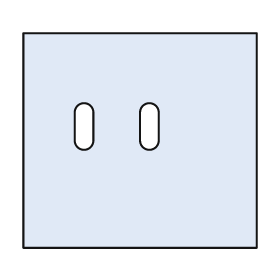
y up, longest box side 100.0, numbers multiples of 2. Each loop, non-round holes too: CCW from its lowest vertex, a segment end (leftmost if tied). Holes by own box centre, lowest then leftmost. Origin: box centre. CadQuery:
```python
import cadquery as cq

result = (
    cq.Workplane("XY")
    .moveTo(-50.0, -46.0)
    .lineTo(50.0, -46.0)
    .lineTo(50.0, 46.0)
    .lineTo(-50.0, 46.0)
    .close()
    .moveTo(-28.0, 0.0)
    .threePointArc((-24.0, -4.0), (-20.0, 0.0))
    .lineTo(-20.0, 12.0)
    .threePointArc((-24.0, 16.0), (-28.0, 12.0))
    .close()
    .moveTo(0.0, 0.0)
    .threePointArc((4.0, -4.0), (8.0, 0.0))
    .lineTo(8.0, 12.0)
    .threePointArc((4.0, 16.0), (0.0, 12.0))
    .close()
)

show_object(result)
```